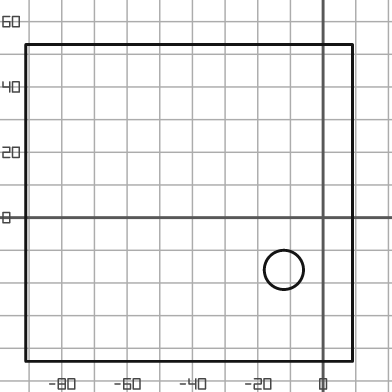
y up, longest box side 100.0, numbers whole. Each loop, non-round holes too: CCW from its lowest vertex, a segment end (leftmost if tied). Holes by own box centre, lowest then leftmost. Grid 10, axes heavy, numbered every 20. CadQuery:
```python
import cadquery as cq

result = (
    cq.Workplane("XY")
    .moveTo(-91.0, -44.0)
    .lineTo(9.0, -44.0)
    .lineTo(9.0, 53.0)
    .lineTo(-91.0, 53.0)
    .close()
    .moveTo(-12.0, -16.0)
    .circle(6.0)
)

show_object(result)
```